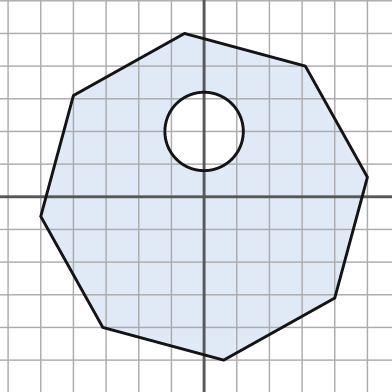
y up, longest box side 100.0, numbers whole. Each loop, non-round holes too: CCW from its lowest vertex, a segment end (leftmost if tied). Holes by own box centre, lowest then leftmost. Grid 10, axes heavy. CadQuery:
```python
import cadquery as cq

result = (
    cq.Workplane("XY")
    .moveTo(6.0, -50.0)
    .lineTo(40.0, -31.0)
    .lineTo(50.0, 6.0)
    .lineTo(31.0, 40.0)
    .lineTo(-6.0, 50.0)
    .lineTo(-40.0, 31.0)
    .lineTo(-50.0, -6.0)
    .lineTo(-31.0, -40.0)
    .close()
    .moveTo(0.0, 20.0)
    .circle(12.0)
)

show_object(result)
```